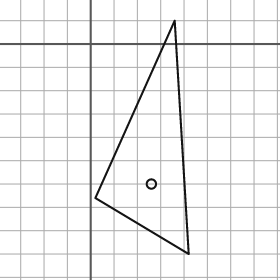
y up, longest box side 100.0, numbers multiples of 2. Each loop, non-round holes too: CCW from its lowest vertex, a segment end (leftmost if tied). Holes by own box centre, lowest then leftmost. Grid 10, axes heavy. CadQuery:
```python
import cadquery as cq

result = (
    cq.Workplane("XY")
    .moveTo(42.0, -90.0)
    .lineTo(36.0, 10.0)
    .lineTo(2.0, -66.0)
    .close()
    .moveTo(26.0, -60.0)
    .circle(2.0)
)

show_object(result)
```